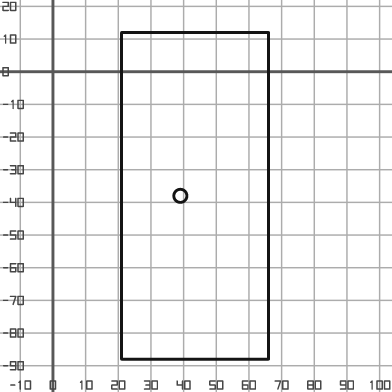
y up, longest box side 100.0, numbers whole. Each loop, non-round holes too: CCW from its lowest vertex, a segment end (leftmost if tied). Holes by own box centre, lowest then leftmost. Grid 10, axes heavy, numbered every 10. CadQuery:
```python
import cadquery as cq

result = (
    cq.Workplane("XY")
    .moveTo(21.0, -88.0)
    .lineTo(66.0, -88.0)
    .lineTo(66.0, 12.0)
    .lineTo(21.0, 12.0)
    .close()
    .moveTo(39.0, -38.0)
    .circle(2.0)
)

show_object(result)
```